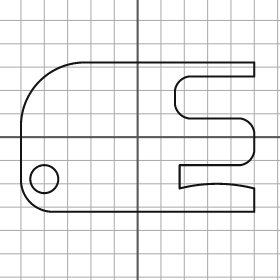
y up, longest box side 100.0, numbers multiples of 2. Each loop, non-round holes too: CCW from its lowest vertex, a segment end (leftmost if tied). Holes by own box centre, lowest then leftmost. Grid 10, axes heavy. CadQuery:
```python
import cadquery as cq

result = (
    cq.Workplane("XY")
    .moveTo(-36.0, -32.0)
    .lineTo(50.0, -32.0)
    .lineTo(50.0, -22.0)
    .threePointArc((34.0, -20.0), (18.0, -22.0))
    .lineTo(18.0, -12.0)
    .lineTo(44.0, -12.0)
    .threePointArc((48.0, -10.0), (50.0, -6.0))
    .lineTo(50.0, 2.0)
    .threePointArc((48.0, 6.0), (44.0, 8.0))
    .lineTo(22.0, 8.0)
    .threePointArc((18.0, 10.0), (16.0, 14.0))
    .lineTo(16.0, 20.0)
    .threePointArc((18.0, 24.0), (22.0, 26.0))
    .lineTo(50.0, 26.0)
    .lineTo(50.0, 32.0)
    .lineTo(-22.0, 32.0)
    .threePointArc((-42.0, 24.0), (-50.0, 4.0))
    .lineTo(-50.0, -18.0)
    .threePointArc((-46.0, -28.0), (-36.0, -32.0))
    .close()
    .moveTo(-40.0, -18.0)
    .circle(6.0)
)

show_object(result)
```